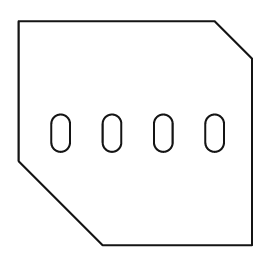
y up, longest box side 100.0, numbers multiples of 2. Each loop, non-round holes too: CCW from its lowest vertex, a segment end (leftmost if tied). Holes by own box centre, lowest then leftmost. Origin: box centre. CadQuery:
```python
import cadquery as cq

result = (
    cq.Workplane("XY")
    .moveTo(-14.0, -48.0)
    .lineTo(50.0, -48.0)
    .lineTo(50.0, 32.0)
    .lineTo(34.0, 48.0)
    .lineTo(-50.0, 48.0)
    .lineTo(-50.0, -12.0)
    .close()
    .moveTo(-36.0, -4.0)
    .threePointArc((-32.0, -8.0), (-28.0, -4.0))
    .lineTo(-28.0, 4.0)
    .threePointArc((-32.0, 8.0), (-36.0, 4.0))
    .close()
    .moveTo(-14.0, -4.0)
    .threePointArc((-10.0, -8.0), (-6.0, -4.0))
    .lineTo(-6.0, 4.0)
    .threePointArc((-10.0, 8.0), (-14.0, 4.0))
    .close()
    .moveTo(8.0, -4.0)
    .threePointArc((12.0, -8.0), (16.0, -4.0))
    .lineTo(16.0, 4.0)
    .threePointArc((12.0, 8.0), (8.0, 4.0))
    .close()
    .moveTo(30.0, -4.0)
    .threePointArc((34.0, -8.0), (38.0, -4.0))
    .lineTo(38.0, 4.0)
    .threePointArc((34.0, 8.0), (30.0, 4.0))
    .close()
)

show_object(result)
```